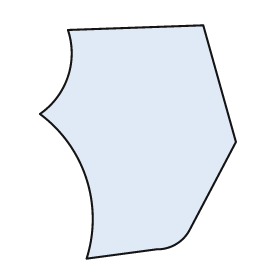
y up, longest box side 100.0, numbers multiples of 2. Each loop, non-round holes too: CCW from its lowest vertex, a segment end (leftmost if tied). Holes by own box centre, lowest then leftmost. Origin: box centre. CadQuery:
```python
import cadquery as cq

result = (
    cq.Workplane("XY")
    .moveTo(-22.0, -50.0)
    .lineTo(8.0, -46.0)
    .threePointArc((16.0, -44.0), (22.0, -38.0))
    .lineTo(42.0, 0.0)
    .lineTo(28.0, 50.0)
    .lineTo(-30.0, 48.0)
    .threePointArc((-30.0, 28.0), (-42.0, 12.0))
    .threePointArc((-22.0, -16.0), (-22.0, -50.0))
    .close()
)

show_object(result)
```